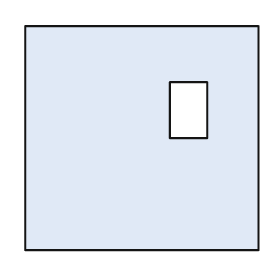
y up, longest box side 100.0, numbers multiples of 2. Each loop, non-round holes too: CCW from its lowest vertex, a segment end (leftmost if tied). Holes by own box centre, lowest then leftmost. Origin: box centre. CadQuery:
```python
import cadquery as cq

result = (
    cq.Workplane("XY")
    .moveTo(-50.0, -48.0)
    .lineTo(50.0, -48.0)
    .lineTo(50.0, 48.0)
    .lineTo(-50.0, 48.0)
    .close()
    .moveTo(12.0, 0.0)
    .lineTo(28.0, 0.0)
    .lineTo(28.0, 24.0)
    .lineTo(12.0, 24.0)
    .close()
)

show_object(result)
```